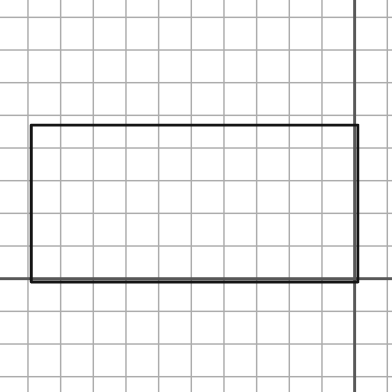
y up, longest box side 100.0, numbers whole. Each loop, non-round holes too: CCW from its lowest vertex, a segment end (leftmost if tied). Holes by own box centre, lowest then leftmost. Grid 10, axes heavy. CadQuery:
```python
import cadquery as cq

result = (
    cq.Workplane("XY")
    .moveTo(-99.0, -1.0)
    .lineTo(1.0, -1.0)
    .lineTo(1.0, 47.0)
    .lineTo(-99.0, 47.0)
    .close()
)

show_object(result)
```